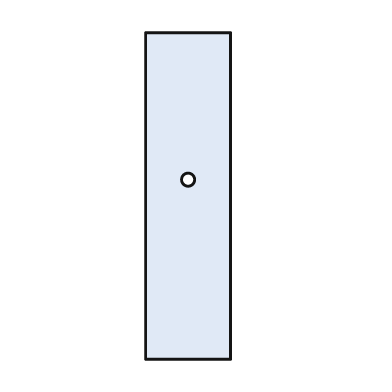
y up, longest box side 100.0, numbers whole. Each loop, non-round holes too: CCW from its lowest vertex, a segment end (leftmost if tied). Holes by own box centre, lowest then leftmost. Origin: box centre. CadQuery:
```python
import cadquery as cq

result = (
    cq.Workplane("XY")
    .moveTo(-13.0, -50.0)
    .lineTo(13.0, -50.0)
    .lineTo(13.0, 50.0)
    .lineTo(-13.0, 50.0)
    .close()
    .moveTo(0.0, 5.0)
    .circle(2.0)
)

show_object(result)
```